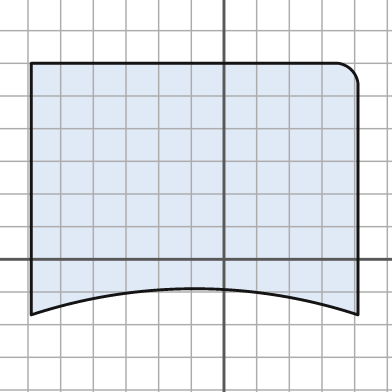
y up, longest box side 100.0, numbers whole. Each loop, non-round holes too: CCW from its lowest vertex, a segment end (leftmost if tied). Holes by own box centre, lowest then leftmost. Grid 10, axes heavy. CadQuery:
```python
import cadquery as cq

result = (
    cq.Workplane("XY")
    .moveTo(-59.0, -17.0)
    .threePointArc((-9.0, -9.0), (41.0, -17.0))
    .lineTo(41.0, 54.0)
    .threePointArc((39.0, 58.0), (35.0, 60.0))
    .lineTo(-59.0, 60.0)
    .close()
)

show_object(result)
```